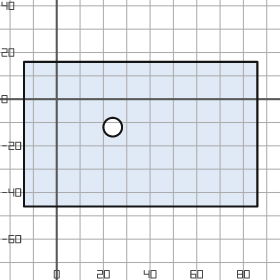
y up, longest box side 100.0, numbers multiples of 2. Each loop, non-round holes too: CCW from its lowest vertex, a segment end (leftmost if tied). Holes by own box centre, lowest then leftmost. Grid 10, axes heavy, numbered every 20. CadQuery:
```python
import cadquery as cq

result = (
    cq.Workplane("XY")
    .moveTo(-14.0, -46.0)
    .lineTo(86.0, -46.0)
    .lineTo(86.0, 16.0)
    .lineTo(-14.0, 16.0)
    .close()
    .moveTo(24.0, -12.0)
    .circle(4.0)
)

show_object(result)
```